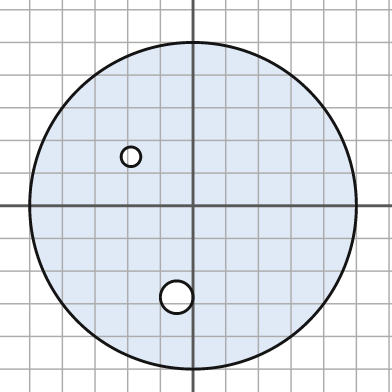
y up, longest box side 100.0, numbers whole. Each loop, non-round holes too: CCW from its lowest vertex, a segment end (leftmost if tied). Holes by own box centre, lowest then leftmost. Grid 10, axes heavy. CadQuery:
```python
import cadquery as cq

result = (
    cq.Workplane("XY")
    .moveTo(0.0, 0.0)
    .circle(50.0)
    .moveTo(-5.0, -28.0)
    .circle(5.0)
    .moveTo(-19.0, 15.0)
    .circle(3.0)
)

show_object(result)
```